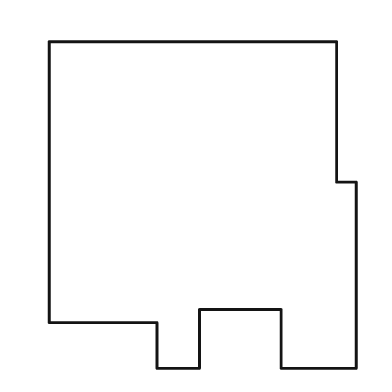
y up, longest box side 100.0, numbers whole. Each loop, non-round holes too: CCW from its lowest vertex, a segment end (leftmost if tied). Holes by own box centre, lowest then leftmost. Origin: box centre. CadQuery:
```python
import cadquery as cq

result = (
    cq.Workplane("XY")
    .moveTo(-14.0, -50.0)
    .lineTo(-1.0, -50.0)
    .lineTo(-1.0, -32.0)
    .lineTo(24.0, -32.0)
    .lineTo(24.0, -50.0)
    .lineTo(47.0, -50.0)
    .lineTo(47.0, 7.0)
    .lineTo(41.0, 7.0)
    .lineTo(41.0, 50.0)
    .lineTo(-47.0, 50.0)
    .lineTo(-47.0, -36.0)
    .lineTo(-14.0, -36.0)
    .close()
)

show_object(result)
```